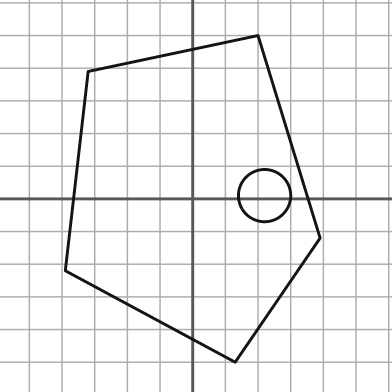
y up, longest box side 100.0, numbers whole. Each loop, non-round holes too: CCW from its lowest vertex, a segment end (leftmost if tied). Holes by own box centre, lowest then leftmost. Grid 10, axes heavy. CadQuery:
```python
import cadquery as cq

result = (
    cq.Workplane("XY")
    .moveTo(13.0, -50.0)
    .lineTo(39.0, -12.0)
    .lineTo(20.0, 50.0)
    .lineTo(-32.0, 39.0)
    .lineTo(-39.0, -22.0)
    .close()
    .moveTo(22.0, 1.0)
    .circle(8.0)
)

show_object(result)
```